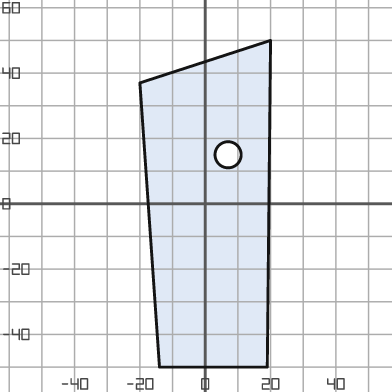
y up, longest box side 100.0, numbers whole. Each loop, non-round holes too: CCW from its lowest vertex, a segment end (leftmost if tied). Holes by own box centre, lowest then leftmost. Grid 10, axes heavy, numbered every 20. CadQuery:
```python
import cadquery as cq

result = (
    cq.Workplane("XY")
    .moveTo(-14.0, -50.0)
    .lineTo(19.0, -50.0)
    .lineTo(20.0, 50.0)
    .lineTo(-20.0, 37.0)
    .close()
    .moveTo(7.0, 15.0)
    .circle(4.0)
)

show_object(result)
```